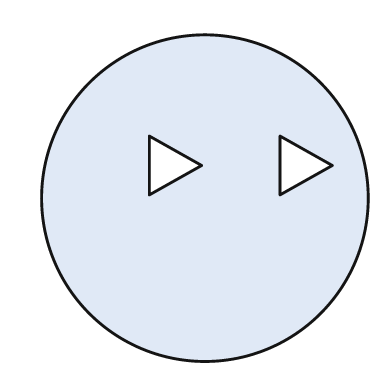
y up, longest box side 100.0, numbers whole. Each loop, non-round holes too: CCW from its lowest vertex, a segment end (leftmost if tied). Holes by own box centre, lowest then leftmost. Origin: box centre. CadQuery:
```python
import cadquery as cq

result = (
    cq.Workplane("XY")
    .moveTo(0.0, 0.0)
    .circle(50.0)
    .moveTo(-17.0, 1.0)
    .lineTo(-1.0, 10.0)
    .lineTo(-17.0, 19.0)
    .close()
    .moveTo(23.0, 1.0)
    .lineTo(39.0, 10.0)
    .lineTo(23.0, 19.0)
    .close()
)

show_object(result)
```